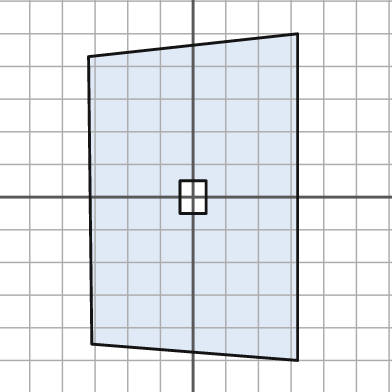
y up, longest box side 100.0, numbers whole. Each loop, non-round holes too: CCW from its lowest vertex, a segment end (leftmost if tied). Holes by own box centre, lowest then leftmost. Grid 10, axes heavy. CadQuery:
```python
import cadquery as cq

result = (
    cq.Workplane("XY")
    .moveTo(32.0, -50.0)
    .lineTo(32.0, 50.0)
    .lineTo(-32.0, 43.0)
    .lineTo(-31.0, -45.0)
    .close()
    .moveTo(-4.0, -5.0)
    .lineTo(4.0, -5.0)
    .lineTo(4.0, 5.0)
    .lineTo(-4.0, 5.0)
    .close()
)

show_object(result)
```